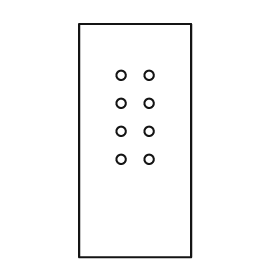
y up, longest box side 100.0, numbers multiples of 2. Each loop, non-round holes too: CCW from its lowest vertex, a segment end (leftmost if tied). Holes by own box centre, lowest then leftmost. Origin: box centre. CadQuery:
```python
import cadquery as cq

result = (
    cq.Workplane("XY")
    .moveTo(-24.0, -50.0)
    .lineTo(24.0, -50.0)
    .lineTo(24.0, 50.0)
    .lineTo(-24.0, 50.0)
    .close()
    .moveTo(-6.0, -8.0)
    .circle(2.0)
    .moveTo(6.0, -8.0)
    .circle(2.0)
    .moveTo(-6.0, 4.0)
    .circle(2.0)
    .moveTo(6.0, 4.0)
    .circle(2.0)
    .moveTo(-6.0, 16.0)
    .circle(2.0)
    .moveTo(6.0, 16.0)
    .circle(2.0)
    .moveTo(-6.0, 28.0)
    .circle(2.0)
    .moveTo(6.0, 28.0)
    .circle(2.0)
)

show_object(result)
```